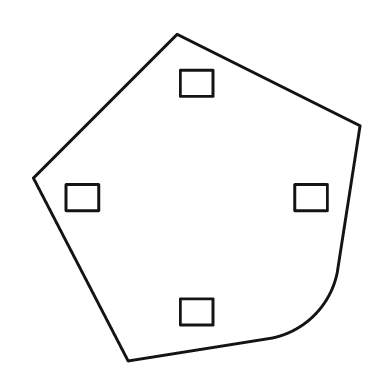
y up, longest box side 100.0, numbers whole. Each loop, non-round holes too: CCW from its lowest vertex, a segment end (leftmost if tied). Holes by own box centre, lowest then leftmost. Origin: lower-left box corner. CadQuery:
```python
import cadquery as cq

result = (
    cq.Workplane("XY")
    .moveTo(29.0, 0.0)
    .lineTo(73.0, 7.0)
    .threePointArc((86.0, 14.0), (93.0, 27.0))
    .lineTo(100.0, 72.0)
    .lineTo(44.0, 100.0)
    .lineTo(0.0, 56.0)
    .close()
    .moveTo(45.0, 11.0)
    .lineTo(55.0, 11.0)
    .lineTo(55.0, 19.0)
    .lineTo(45.0, 19.0)
    .close()
    .moveTo(10.0, 46.0)
    .lineTo(20.0, 46.0)
    .lineTo(20.0, 54.0)
    .lineTo(10.0, 54.0)
    .close()
    .moveTo(80.0, 46.0)
    .lineTo(90.0, 46.0)
    .lineTo(90.0, 54.0)
    .lineTo(80.0, 54.0)
    .close()
    .moveTo(45.0, 81.0)
    .lineTo(55.0, 81.0)
    .lineTo(55.0, 89.0)
    .lineTo(45.0, 89.0)
    .close()
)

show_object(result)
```